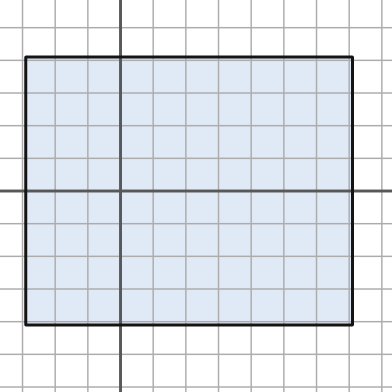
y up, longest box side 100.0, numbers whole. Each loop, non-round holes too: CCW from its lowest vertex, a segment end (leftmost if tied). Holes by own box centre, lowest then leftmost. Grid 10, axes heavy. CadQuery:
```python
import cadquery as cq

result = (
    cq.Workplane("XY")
    .moveTo(-29.0, -41.0)
    .lineTo(71.0, -41.0)
    .lineTo(71.0, 41.0)
    .lineTo(-29.0, 41.0)
    .close()
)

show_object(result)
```